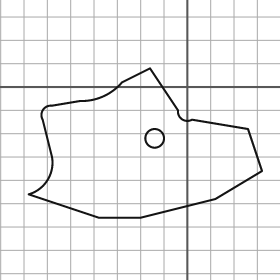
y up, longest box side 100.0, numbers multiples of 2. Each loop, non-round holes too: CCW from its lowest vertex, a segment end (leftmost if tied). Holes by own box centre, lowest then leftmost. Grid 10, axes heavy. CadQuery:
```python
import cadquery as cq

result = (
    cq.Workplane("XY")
    .moveTo(-38.0, -56.0)
    .lineTo(-20.0, -56.0)
    .lineTo(12.0, -48.0)
    .lineTo(32.0, -36.0)
    .lineTo(26.0, -18.0)
    .lineTo(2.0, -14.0)
    .threePointArc((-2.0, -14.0), (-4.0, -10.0))
    .lineTo(-16.0, 8.0)
    .lineTo(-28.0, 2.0)
    .threePointArc((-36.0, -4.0), (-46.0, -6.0))
    .lineTo(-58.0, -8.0)
    .threePointArc((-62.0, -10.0), (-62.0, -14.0))
    .lineTo(-58.0, -30.0)
    .threePointArc((-60.0, -40.0), (-68.0, -46.0))
    .close()
    .moveTo(-14.0, -22.0)
    .circle(4.0)
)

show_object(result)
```